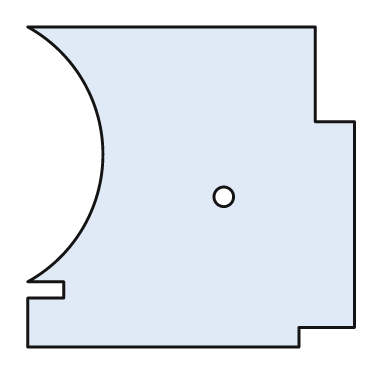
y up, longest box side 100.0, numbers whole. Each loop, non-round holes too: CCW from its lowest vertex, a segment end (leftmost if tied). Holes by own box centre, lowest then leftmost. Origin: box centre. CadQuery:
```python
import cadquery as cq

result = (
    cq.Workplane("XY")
    .moveTo(-50.0, -49.0)
    .lineTo(33.0, -49.0)
    .lineTo(33.0, -43.0)
    .lineTo(50.0, -43.0)
    .lineTo(50.0, 20.0)
    .lineTo(38.0, 20.0)
    .lineTo(38.0, 49.0)
    .lineTo(-50.0, 49.0)
    .threePointArc((-27.0, 10.0), (-50.0, -29.0))
    .lineTo(-39.0, -29.0)
    .lineTo(-39.0, -34.0)
    .lineTo(-50.0, -34.0)
    .close()
    .moveTo(10.0, -3.0)
    .circle(3.0)
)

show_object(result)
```